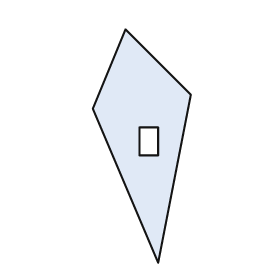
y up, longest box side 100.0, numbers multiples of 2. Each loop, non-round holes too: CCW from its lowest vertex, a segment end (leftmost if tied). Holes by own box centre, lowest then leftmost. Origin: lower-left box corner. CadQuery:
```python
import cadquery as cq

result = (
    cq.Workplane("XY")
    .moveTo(28.0, 0.0)
    .lineTo(42.0, 72.0)
    .lineTo(14.0, 100.0)
    .lineTo(0.0, 66.0)
    .close()
    .moveTo(20.0, 46.0)
    .lineTo(28.0, 46.0)
    .lineTo(28.0, 58.0)
    .lineTo(20.0, 58.0)
    .close()
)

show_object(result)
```